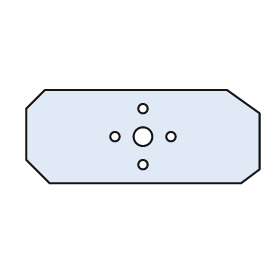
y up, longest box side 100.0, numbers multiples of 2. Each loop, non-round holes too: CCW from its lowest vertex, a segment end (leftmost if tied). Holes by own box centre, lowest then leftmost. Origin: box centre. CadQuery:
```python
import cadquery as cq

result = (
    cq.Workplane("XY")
    .moveTo(-40.0, -20.0)
    .lineTo(42.0, -20.0)
    .lineTo(50.0, -14.0)
    .lineTo(50.0, 10.0)
    .lineTo(36.0, 20.0)
    .lineTo(-42.0, 20.0)
    .lineTo(-50.0, 12.0)
    .lineTo(-50.0, -10.0)
    .close()
    .moveTo(0.0, -12.0)
    .circle(2.0)
    .moveTo(-12.0, 0.0)
    .circle(2.0)
    .moveTo(0.0, 0.0)
    .circle(4.0)
    .moveTo(12.0, 0.0)
    .circle(2.0)
    .moveTo(0.0, 12.0)
    .circle(2.0)
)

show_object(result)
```